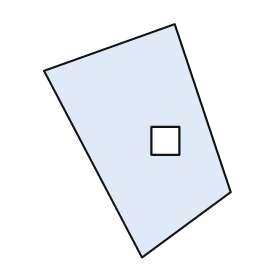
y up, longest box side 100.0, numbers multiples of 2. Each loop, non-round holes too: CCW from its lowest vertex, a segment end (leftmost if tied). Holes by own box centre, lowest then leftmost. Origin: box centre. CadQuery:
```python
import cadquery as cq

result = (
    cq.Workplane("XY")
    .moveTo(2.0, -50.0)
    .lineTo(40.0, -22.0)
    .lineTo(16.0, 50.0)
    .lineTo(-40.0, 30.0)
    .close()
    .moveTo(6.0, -6.0)
    .lineTo(18.0, -6.0)
    .lineTo(18.0, 6.0)
    .lineTo(6.0, 6.0)
    .close()
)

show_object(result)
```